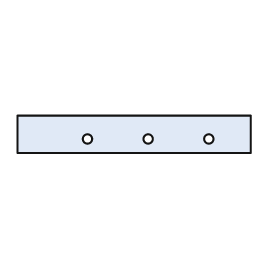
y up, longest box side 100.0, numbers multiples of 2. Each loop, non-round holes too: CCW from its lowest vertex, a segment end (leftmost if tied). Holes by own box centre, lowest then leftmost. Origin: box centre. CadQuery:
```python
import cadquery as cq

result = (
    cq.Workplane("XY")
    .moveTo(-50.0, -8.0)
    .lineTo(50.0, -8.0)
    .lineTo(50.0, 8.0)
    .lineTo(-50.0, 8.0)
    .close()
    .moveTo(-20.0, -2.0)
    .circle(2.0)
    .moveTo(6.0, -2.0)
    .circle(2.0)
    .moveTo(32.0, -2.0)
    .circle(2.0)
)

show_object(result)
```